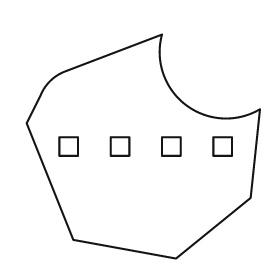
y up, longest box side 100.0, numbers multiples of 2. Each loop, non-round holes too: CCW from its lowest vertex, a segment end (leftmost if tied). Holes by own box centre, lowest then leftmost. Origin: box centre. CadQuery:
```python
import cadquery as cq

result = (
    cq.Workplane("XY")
    .moveTo(14.0, -48.0)
    .lineTo(46.0, -22.0)
    .lineTo(50.0, 16.0)
    .threePointArc((18.0, 18.0), (8.0, 48.0))
    .lineTo(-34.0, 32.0)
    .threePointArc((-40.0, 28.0), (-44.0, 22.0))
    .lineTo(-50.0, 10.0)
    .lineTo(-30.0, -40.0)
    .close()
    .moveTo(-36.0, -4.0)
    .lineTo(-28.0, -4.0)
    .lineTo(-28.0, 4.0)
    .lineTo(-36.0, 4.0)
    .close()
    .moveTo(-14.0, -4.0)
    .lineTo(-6.0, -4.0)
    .lineTo(-6.0, 4.0)
    .lineTo(-14.0, 4.0)
    .close()
    .moveTo(8.0, -4.0)
    .lineTo(16.0, -4.0)
    .lineTo(16.0, 4.0)
    .lineTo(8.0, 4.0)
    .close()
    .moveTo(30.0, -4.0)
    .lineTo(38.0, -4.0)
    .lineTo(38.0, 4.0)
    .lineTo(30.0, 4.0)
    .close()
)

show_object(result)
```